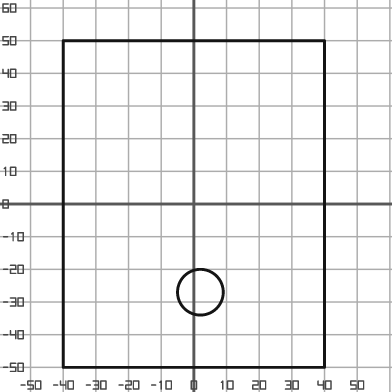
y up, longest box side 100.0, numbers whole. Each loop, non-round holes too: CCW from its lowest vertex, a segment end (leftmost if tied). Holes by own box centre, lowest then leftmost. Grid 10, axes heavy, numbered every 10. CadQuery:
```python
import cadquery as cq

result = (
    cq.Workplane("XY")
    .moveTo(-40.0, -50.0)
    .lineTo(40.0, -50.0)
    .lineTo(40.0, 50.0)
    .lineTo(-40.0, 50.0)
    .close()
    .moveTo(2.0, -27.0)
    .circle(7.0)
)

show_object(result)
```